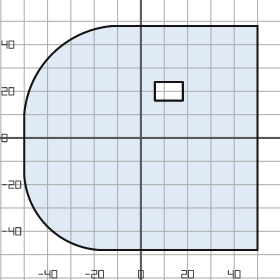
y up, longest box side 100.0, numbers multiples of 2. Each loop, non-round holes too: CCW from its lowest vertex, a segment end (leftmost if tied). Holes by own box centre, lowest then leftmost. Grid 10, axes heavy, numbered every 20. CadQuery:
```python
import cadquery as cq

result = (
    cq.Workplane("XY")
    .moveTo(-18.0, -48.0)
    .lineTo(50.0, -48.0)
    .lineTo(50.0, 48.0)
    .lineTo(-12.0, 48.0)
    .threePointArc((-38.0, 36.0), (-50.0, 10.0))
    .lineTo(-50.0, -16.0)
    .threePointArc((-40.0, -38.0), (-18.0, -48.0))
    .close()
    .moveTo(6.0, 16.0)
    .lineTo(18.0, 16.0)
    .lineTo(18.0, 24.0)
    .lineTo(6.0, 24.0)
    .close()
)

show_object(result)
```